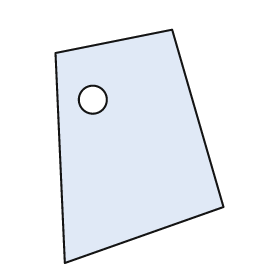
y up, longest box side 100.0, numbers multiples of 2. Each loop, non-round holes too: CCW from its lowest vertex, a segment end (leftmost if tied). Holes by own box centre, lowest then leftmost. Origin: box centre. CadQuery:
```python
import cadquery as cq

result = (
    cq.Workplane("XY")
    .moveTo(-32.0, -50.0)
    .lineTo(36.0, -26.0)
    .lineTo(14.0, 50.0)
    .lineTo(-36.0, 40.0)
    .close()
    .moveTo(-20.0, 20.0)
    .circle(6.0)
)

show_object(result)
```